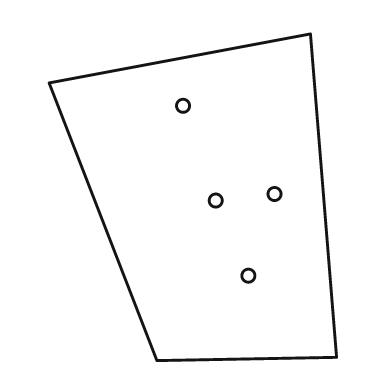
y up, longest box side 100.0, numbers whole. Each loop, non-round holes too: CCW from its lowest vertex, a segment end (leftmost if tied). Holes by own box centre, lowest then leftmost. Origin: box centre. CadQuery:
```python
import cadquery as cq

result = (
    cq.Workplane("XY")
    .moveTo(-11.0, -50.0)
    .lineTo(44.0, -49.0)
    .lineTo(36.0, 50.0)
    .lineTo(-44.0, 35.0)
    .close()
    .moveTo(17.0, -24.0)
    .circle(2.0)
    .moveTo(7.0, -1.0)
    .circle(2.0)
    .moveTo(25.0, 1.0)
    .circle(2.0)
    .moveTo(-3.0, 28.0)
    .circle(2.0)
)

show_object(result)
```